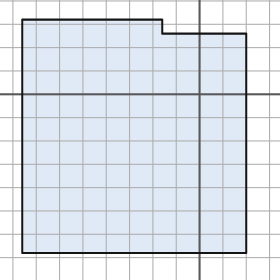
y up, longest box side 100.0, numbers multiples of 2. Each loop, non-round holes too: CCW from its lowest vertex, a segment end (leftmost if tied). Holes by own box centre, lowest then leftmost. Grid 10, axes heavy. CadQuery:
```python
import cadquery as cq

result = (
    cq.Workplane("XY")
    .moveTo(-76.0, -68.0)
    .lineTo(20.0, -68.0)
    .lineTo(20.0, 26.0)
    .lineTo(-16.0, 26.0)
    .lineTo(-16.0, 32.0)
    .lineTo(-76.0, 32.0)
    .close()
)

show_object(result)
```